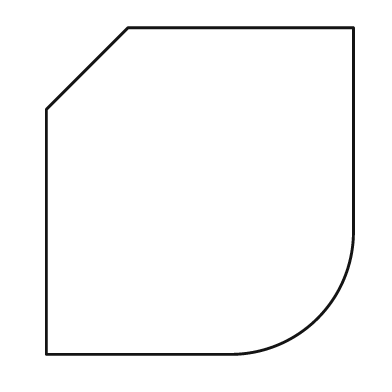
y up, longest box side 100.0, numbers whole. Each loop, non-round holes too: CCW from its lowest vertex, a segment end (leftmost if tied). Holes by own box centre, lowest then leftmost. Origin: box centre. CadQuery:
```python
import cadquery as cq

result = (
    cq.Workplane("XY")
    .moveTo(-47.0, -50.0)
    .lineTo(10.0, -50.0)
    .threePointArc((36.0, -39.0), (47.0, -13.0))
    .lineTo(47.0, 50.0)
    .lineTo(-22.0, 50.0)
    .lineTo(-47.0, 25.0)
    .close()
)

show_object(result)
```